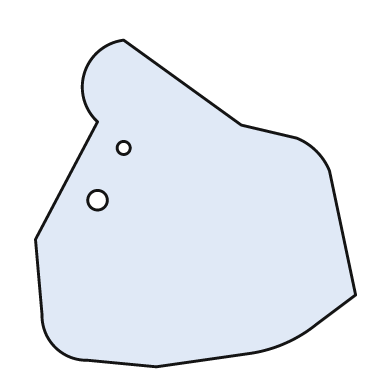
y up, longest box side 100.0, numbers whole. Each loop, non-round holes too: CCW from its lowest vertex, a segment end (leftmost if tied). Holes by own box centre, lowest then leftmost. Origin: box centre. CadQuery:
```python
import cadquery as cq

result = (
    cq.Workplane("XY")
    .moveTo(-12.0, -50.0)
    .lineTo(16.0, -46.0)
    .threePointArc((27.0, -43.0), (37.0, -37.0))
    .lineTo(49.0, -28.0)
    .lineTo(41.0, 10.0)
    .threePointArc((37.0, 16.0), (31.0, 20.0))
    .lineTo(14.0, 24.0)
    .lineTo(-22.0, 50.0)
    .threePointArc((-34.0, 40.0), (-30.0, 25.0))
    .lineTo(-49.0, -11.0)
    .lineTo(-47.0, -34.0)
    .threePointArc((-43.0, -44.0), (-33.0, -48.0))
    .close()
    .moveTo(-30.0, 1.0)
    .circle(3.0)
    .moveTo(-22.0, 17.0)
    .circle(2.0)
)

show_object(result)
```